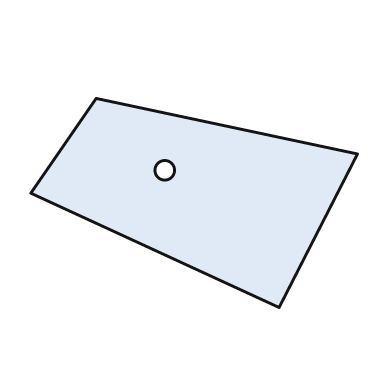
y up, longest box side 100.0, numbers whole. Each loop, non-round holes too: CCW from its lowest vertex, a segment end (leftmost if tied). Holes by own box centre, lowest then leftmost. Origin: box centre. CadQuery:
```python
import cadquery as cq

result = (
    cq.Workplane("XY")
    .moveTo(26.0, -32.0)
    .lineTo(50.0, 15.0)
    .lineTo(-30.0, 32.0)
    .lineTo(-50.0, 3.0)
    .close()
    .moveTo(-9.0, 10.0)
    .circle(3.0)
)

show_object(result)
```